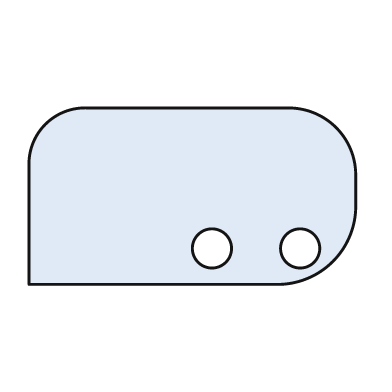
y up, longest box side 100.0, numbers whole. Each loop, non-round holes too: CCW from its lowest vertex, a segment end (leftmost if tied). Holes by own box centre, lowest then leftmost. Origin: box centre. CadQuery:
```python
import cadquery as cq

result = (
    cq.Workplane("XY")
    .moveTo(-50.0, -27.0)
    .lineTo(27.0, -27.0)
    .threePointArc((43.0, -20.0), (50.0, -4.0))
    .lineTo(50.0, 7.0)
    .threePointArc((44.0, 21.0), (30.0, 27.0))
    .lineTo(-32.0, 27.0)
    .threePointArc((-45.0, 22.0), (-50.0, 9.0))
    .close()
    .moveTo(6.0, -16.0)
    .circle(6.0)
    .moveTo(33.0, -16.0)
    .circle(6.0)
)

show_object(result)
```